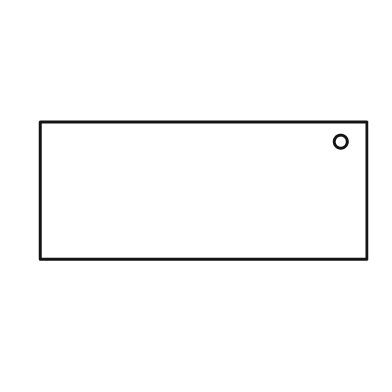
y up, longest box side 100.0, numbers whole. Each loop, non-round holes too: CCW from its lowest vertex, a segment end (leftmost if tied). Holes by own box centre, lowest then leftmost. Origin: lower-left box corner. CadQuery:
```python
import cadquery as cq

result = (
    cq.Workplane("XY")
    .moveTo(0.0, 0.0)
    .lineTo(100.0, 0.0)
    .lineTo(100.0, 42.0)
    .lineTo(0.0, 42.0)
    .close()
    .moveTo(92.0, 36.0)
    .circle(2.0)
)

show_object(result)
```